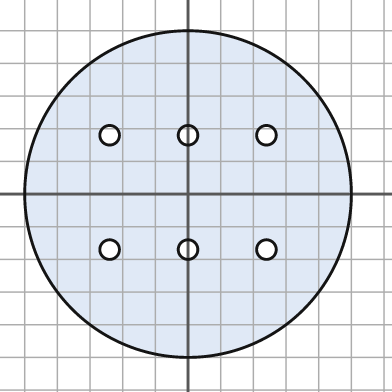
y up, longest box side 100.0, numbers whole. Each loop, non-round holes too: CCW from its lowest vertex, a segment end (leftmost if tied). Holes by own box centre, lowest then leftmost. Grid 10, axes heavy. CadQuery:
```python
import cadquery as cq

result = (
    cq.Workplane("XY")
    .moveTo(0.0, 0.0)
    .circle(50.0)
    .moveTo(-24.0, -17.0)
    .circle(3.0)
    .moveTo(0.0, -17.0)
    .circle(3.0)
    .moveTo(24.0, -17.0)
    .circle(3.0)
    .moveTo(-24.0, 18.0)
    .circle(3.0)
    .moveTo(0.0, 18.0)
    .circle(3.0)
    .moveTo(24.0, 18.0)
    .circle(3.0)
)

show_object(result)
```